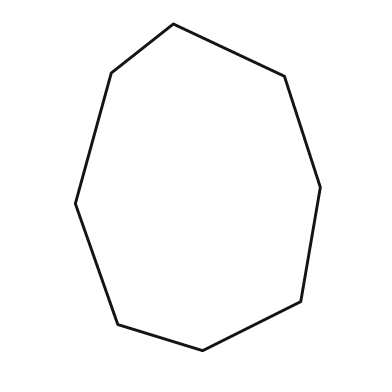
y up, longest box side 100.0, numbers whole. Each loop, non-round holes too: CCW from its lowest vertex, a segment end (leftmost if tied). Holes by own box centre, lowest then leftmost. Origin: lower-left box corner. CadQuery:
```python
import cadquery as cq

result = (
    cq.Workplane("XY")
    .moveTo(39.0, 0.0)
    .lineTo(69.0, 15.0)
    .lineTo(75.0, 50.0)
    .lineTo(64.0, 84.0)
    .lineTo(30.0, 100.0)
    .lineTo(11.0, 85.0)
    .lineTo(0.0, 45.0)
    .lineTo(13.0, 8.0)
    .close()
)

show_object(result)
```